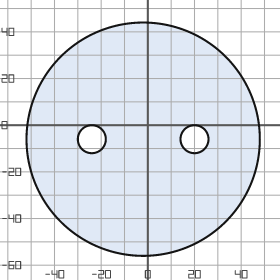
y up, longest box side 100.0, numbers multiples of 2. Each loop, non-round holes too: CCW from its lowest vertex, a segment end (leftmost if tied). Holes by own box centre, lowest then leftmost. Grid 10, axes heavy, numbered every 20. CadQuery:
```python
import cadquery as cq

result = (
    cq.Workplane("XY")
    .moveTo(-2.0, -6.0)
    .circle(50.0)
    .moveTo(-24.0, -6.0)
    .circle(6.0)
    .moveTo(20.0, -6.0)
    .circle(6.0)
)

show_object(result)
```